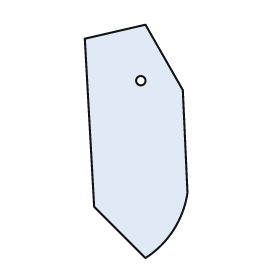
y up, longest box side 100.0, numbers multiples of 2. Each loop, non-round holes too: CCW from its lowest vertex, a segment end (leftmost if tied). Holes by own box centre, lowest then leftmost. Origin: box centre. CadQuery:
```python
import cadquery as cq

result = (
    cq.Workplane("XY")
    .moveTo(4.0, -50.0)
    .threePointArc((16.0, -38.0), (22.0, -22.0))
    .lineTo(20.0, 22.0)
    .lineTo(4.0, 50.0)
    .lineTo(-22.0, 44.0)
    .lineTo(-18.0, -28.0)
    .close()
    .moveTo(2.0, 26.0)
    .circle(2.0)
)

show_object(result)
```